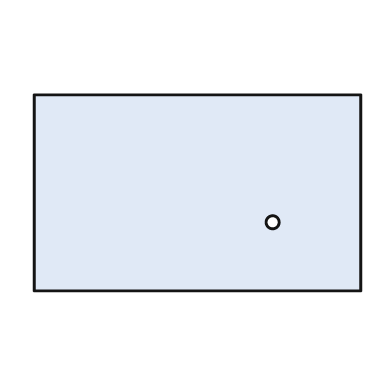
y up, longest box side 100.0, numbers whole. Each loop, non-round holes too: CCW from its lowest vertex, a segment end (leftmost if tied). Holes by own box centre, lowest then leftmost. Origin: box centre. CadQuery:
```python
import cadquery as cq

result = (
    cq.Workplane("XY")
    .moveTo(-50.0, -30.0)
    .lineTo(50.0, -30.0)
    .lineTo(50.0, 30.0)
    .lineTo(-50.0, 30.0)
    .close()
    .moveTo(23.0, -9.0)
    .circle(2.0)
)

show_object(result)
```